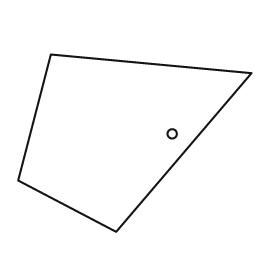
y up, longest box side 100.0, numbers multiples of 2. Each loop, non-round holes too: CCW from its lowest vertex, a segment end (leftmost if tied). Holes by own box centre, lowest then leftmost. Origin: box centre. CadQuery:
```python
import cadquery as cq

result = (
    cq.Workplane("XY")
    .moveTo(-8.0, -38.0)
    .lineTo(50.0, 30.0)
    .lineTo(-36.0, 38.0)
    .lineTo(-50.0, -16.0)
    .close()
    .moveTo(16.0, 4.0)
    .circle(2.0)
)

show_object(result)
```